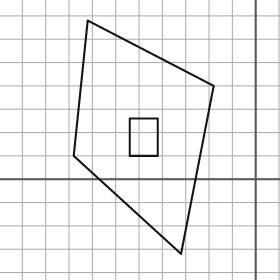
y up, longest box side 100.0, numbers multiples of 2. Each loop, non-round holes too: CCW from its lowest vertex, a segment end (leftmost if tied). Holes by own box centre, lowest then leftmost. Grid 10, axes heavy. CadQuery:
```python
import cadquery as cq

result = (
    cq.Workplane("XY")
    .moveTo(-32.0, -32.0)
    .lineTo(-18.0, 40.0)
    .lineTo(-72.0, 68.0)
    .lineTo(-78.0, 10.0)
    .close()
    .moveTo(-54.0, 10.0)
    .lineTo(-42.0, 10.0)
    .lineTo(-42.0, 26.0)
    .lineTo(-54.0, 26.0)
    .close()
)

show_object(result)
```